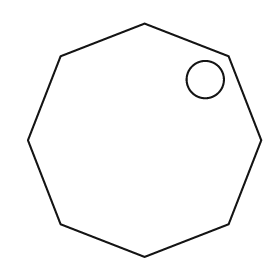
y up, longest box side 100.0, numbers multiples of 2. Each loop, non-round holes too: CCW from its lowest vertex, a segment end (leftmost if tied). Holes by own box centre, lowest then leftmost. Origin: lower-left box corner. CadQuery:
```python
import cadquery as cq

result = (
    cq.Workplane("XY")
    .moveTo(50.0, 0.0)
    .lineTo(86.0, 14.0)
    .lineTo(100.0, 50.0)
    .lineTo(86.0, 86.0)
    .lineTo(50.0, 100.0)
    .lineTo(14.0, 86.0)
    .lineTo(0.0, 50.0)
    .lineTo(14.0, 14.0)
    .close()
    .moveTo(76.0, 76.0)
    .circle(8.0)
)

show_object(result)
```